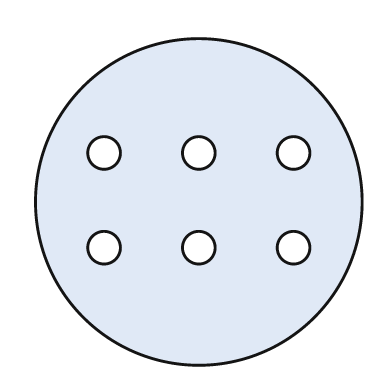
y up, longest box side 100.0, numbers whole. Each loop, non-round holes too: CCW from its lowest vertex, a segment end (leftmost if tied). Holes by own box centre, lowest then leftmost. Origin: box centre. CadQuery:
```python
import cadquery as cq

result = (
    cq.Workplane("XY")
    .moveTo(0.0, 0.0)
    .circle(50.0)
    .moveTo(-29.0, -14.0)
    .circle(5.0)
    .moveTo(0.0, -14.0)
    .circle(5.0)
    .moveTo(29.0, -14.0)
    .circle(5.0)
    .moveTo(-29.0, 15.0)
    .circle(5.0)
    .moveTo(0.0, 15.0)
    .circle(5.0)
    .moveTo(29.0, 15.0)
    .circle(5.0)
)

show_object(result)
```